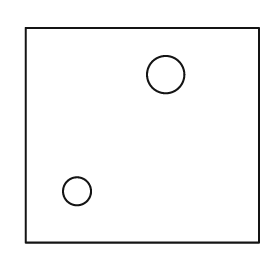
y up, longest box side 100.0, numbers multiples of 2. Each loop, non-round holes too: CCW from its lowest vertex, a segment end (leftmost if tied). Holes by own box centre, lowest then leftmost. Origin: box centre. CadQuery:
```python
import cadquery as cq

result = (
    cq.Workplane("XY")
    .moveTo(-50.0, -46.0)
    .lineTo(50.0, -46.0)
    .lineTo(50.0, 46.0)
    .lineTo(-50.0, 46.0)
    .close()
    .moveTo(-28.0, -24.0)
    .circle(6.0)
    .moveTo(10.0, 26.0)
    .circle(8.0)
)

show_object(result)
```